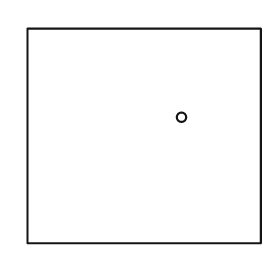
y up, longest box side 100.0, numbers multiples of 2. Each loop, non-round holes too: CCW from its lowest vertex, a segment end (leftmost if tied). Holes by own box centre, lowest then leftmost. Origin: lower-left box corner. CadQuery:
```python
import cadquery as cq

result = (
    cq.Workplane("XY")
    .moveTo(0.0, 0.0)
    .lineTo(100.0, 0.0)
    .lineTo(100.0, 92.0)
    .lineTo(0.0, 92.0)
    .close()
    .moveTo(66.0, 54.0)
    .circle(2.0)
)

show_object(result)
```